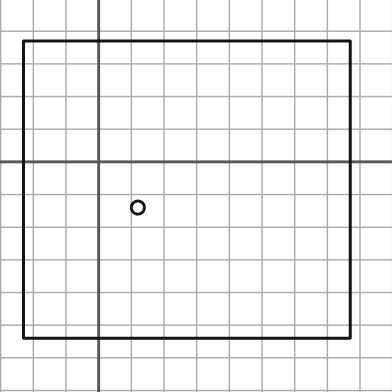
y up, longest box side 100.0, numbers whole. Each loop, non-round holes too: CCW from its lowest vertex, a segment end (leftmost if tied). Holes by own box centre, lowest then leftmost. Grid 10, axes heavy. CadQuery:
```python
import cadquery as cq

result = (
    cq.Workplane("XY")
    .moveTo(-23.0, -54.0)
    .lineTo(77.0, -54.0)
    .lineTo(77.0, 37.0)
    .lineTo(-23.0, 37.0)
    .close()
    .moveTo(12.0, -14.0)
    .circle(2.0)
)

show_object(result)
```